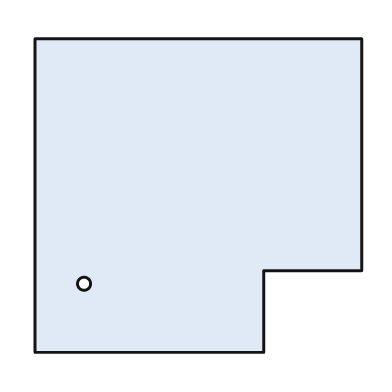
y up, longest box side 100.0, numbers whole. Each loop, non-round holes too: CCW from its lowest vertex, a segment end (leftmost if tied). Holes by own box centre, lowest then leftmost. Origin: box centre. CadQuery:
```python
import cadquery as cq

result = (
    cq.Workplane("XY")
    .moveTo(-50.0, -48.0)
    .lineTo(20.0, -48.0)
    .lineTo(20.0, -23.0)
    .lineTo(50.0, -23.0)
    .lineTo(50.0, 48.0)
    .lineTo(-50.0, 48.0)
    .close()
    .moveTo(-35.0, -27.0)
    .circle(2.0)
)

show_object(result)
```